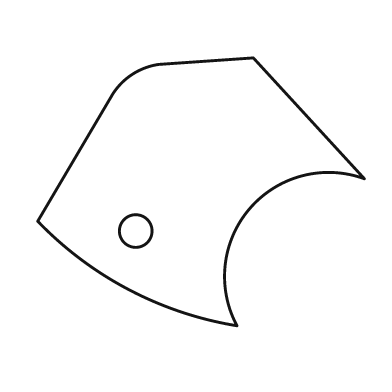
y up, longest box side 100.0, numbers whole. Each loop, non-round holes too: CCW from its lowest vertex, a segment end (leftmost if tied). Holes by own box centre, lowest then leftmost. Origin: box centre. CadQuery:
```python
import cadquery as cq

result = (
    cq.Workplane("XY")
    .moveTo(11.0, -41.0)
    .threePointArc((15.0, -5.0), (50.0, 4.0))
    .lineTo(16.0, 41.0)
    .lineTo(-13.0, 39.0)
    .threePointArc((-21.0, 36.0), (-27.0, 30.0))
    .lineTo(-50.0, -9.0)
    .threePointArc((-22.0, -30.0), (11.0, -41.0))
    .close()
    .moveTo(-20.0, -12.0)
    .circle(5.0)
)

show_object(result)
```